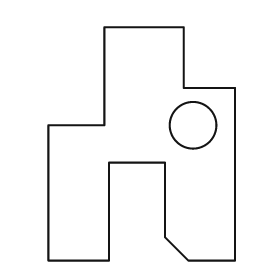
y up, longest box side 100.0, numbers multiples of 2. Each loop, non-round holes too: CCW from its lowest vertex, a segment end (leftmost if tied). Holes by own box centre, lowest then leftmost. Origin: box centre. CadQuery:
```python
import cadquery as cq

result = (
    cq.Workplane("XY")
    .moveTo(-40.0, -50.0)
    .lineTo(-14.0, -50.0)
    .lineTo(-14.0, -8.0)
    .lineTo(10.0, -8.0)
    .lineTo(10.0, -40.0)
    .lineTo(20.0, -50.0)
    .lineTo(40.0, -50.0)
    .lineTo(40.0, 24.0)
    .lineTo(18.0, 24.0)
    .lineTo(18.0, 50.0)
    .lineTo(-16.0, 50.0)
    .lineTo(-16.0, 8.0)
    .lineTo(-40.0, 8.0)
    .close()
    .moveTo(22.0, 8.0)
    .circle(10.0)
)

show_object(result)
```